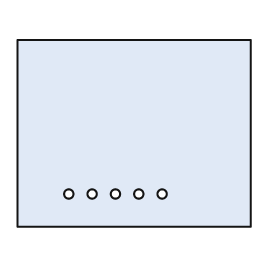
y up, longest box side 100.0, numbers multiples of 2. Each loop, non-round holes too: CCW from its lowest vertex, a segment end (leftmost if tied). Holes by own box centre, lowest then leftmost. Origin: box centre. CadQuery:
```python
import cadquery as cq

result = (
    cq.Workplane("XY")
    .moveTo(-50.0, -40.0)
    .lineTo(50.0, -40.0)
    .lineTo(50.0, 40.0)
    .lineTo(-50.0, 40.0)
    .close()
    .moveTo(-28.0, -26.0)
    .circle(2.0)
    .moveTo(-18.0, -26.0)
    .circle(2.0)
    .moveTo(-8.0, -26.0)
    .circle(2.0)
    .moveTo(2.0, -26.0)
    .circle(2.0)
    .moveTo(12.0, -26.0)
    .circle(2.0)
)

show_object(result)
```